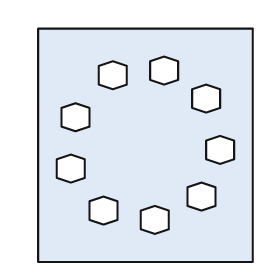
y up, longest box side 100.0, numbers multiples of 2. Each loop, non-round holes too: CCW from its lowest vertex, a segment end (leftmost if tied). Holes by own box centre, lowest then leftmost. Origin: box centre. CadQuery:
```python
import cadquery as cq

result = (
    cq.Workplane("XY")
    .moveTo(-46.0, -50.0)
    .lineTo(46.0, -50.0)
    .lineTo(46.0, 50.0)
    .lineTo(-46.0, 50.0)
    .close()
    .moveTo(4.0, -38.0)
    .lineTo(10.0, -36.0)
    .lineTo(10.0, -28.0)
    .lineTo(4.0, -26.0)
    .lineTo(-2.0, -28.0)
    .lineTo(-2.0, -36.0)
    .close()
    .moveTo(-18.0, -34.0)
    .lineTo(-12.0, -32.0)
    .lineTo(-12.0, -24.0)
    .lineTo(-18.0, -22.0)
    .lineTo(-24.0, -24.0)
    .lineTo(-24.0, -32.0)
    .close()
    .moveTo(24.0, -28.0)
    .lineTo(30.0, -26.0)
    .lineTo(30.0, -18.0)
    .lineTo(24.0, -16.0)
    .lineTo(18.0, -18.0)
    .lineTo(18.0, -26.0)
    .close()
    .moveTo(-32.0, -16.0)
    .lineTo(-26.0, -14.0)
    .lineTo(-26.0, -6.0)
    .lineTo(-32.0, -4.0)
    .lineTo(-38.0, -6.0)
    .lineTo(-38.0, -14.0)
    .close()
    .moveTo(32.0, -8.0)
    .lineTo(38.0, -6.0)
    .lineTo(38.0, 2.0)
    .lineTo(32.0, 4.0)
    .lineTo(26.0, 2.0)
    .lineTo(26.0, -6.0)
    .close()
    .moveTo(-30.0, 6.0)
    .lineTo(-24.0, 8.0)
    .lineTo(-24.0, 16.0)
    .lineTo(-30.0, 18.0)
    .lineTo(-36.0, 16.0)
    .lineTo(-36.0, 8.0)
    .close()
    .moveTo(26.0, 14.0)
    .lineTo(32.0, 16.0)
    .lineTo(32.0, 24.0)
    .lineTo(26.0, 26.0)
    .lineTo(20.0, 24.0)
    .lineTo(20.0, 16.0)
    .close()
    .moveTo(-14.0, 24.0)
    .lineTo(-8.0, 26.0)
    .lineTo(-8.0, 34.0)
    .lineTo(-14.0, 36.0)
    .lineTo(-20.0, 34.0)
    .lineTo(-20.0, 26.0)
    .close()
    .moveTo(8.0, 26.0)
    .lineTo(14.0, 28.0)
    .lineTo(14.0, 36.0)
    .lineTo(8.0, 38.0)
    .lineTo(2.0, 36.0)
    .lineTo(2.0, 28.0)
    .close()
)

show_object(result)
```